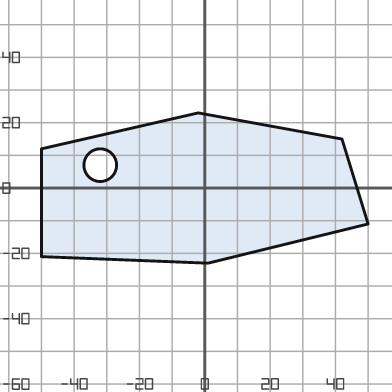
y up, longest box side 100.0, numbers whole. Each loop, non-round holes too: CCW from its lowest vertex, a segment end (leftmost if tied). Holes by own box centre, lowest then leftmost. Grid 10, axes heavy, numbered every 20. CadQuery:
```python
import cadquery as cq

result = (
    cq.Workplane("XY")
    .moveTo(1.0, -23.0)
    .lineTo(50.0, -11.0)
    .lineTo(42.0, 15.0)
    .lineTo(-2.0, 23.0)
    .lineTo(-50.0, 12.0)
    .lineTo(-50.0, -21.0)
    .close()
    .moveTo(-32.0, 7.0)
    .circle(5.0)
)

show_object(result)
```